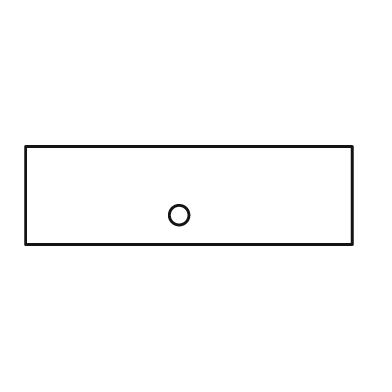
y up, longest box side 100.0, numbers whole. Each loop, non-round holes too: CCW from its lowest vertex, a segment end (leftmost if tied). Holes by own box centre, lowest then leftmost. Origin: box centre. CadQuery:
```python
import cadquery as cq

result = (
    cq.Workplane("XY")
    .moveTo(-50.0, -15.0)
    .lineTo(50.0, -15.0)
    .lineTo(50.0, 15.0)
    .lineTo(-50.0, 15.0)
    .close()
    .moveTo(-3.0, -6.0)
    .circle(3.0)
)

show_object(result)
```